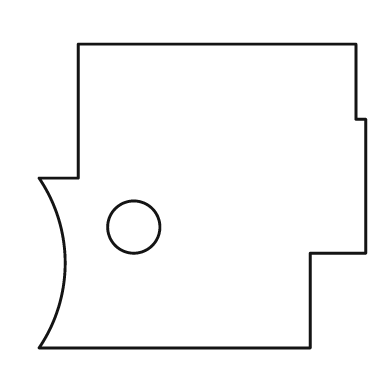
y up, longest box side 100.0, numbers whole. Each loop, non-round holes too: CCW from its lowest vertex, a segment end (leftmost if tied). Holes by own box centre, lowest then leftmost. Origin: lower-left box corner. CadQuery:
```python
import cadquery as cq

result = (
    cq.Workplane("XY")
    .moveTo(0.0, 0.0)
    .lineTo(83.0, 0.0)
    .lineTo(83.0, 29.0)
    .lineTo(100.0, 29.0)
    .lineTo(100.0, 70.0)
    .lineTo(97.0, 70.0)
    .lineTo(97.0, 93.0)
    .lineTo(12.0, 93.0)
    .lineTo(12.0, 52.0)
    .lineTo(0.0, 52.0)
    .threePointArc((8.0, 26.0), (0.0, 0.0))
    .close()
    .moveTo(29.0, 37.0)
    .circle(8.0)
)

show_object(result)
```